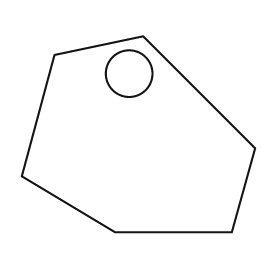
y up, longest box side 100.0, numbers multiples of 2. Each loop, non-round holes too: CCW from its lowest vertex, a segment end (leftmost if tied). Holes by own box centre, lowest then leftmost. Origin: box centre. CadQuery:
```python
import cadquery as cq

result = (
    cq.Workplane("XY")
    .moveTo(-10.0, -42.0)
    .lineTo(40.0, -42.0)
    .lineTo(50.0, -6.0)
    .lineTo(2.0, 42.0)
    .lineTo(-36.0, 34.0)
    .lineTo(-50.0, -18.0)
    .close()
    .moveTo(-4.0, 26.0)
    .circle(10.0)
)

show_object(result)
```